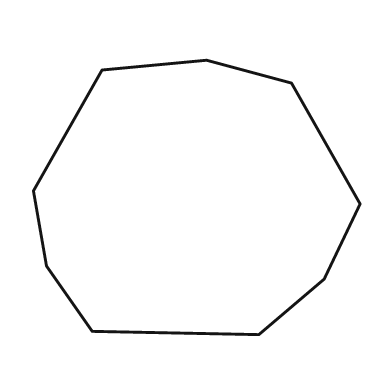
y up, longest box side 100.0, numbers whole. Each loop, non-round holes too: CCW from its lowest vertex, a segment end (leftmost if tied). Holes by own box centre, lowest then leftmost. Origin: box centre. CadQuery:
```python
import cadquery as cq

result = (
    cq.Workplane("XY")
    .moveTo(19.0, -42.0)
    .lineTo(39.0, -25.0)
    .lineTo(50.0, -2.0)
    .lineTo(29.0, 35.0)
    .lineTo(3.0, 42.0)
    .lineTo(-29.0, 39.0)
    .lineTo(-50.0, 2.0)
    .lineTo(-46.0, -21.0)
    .lineTo(-32.0, -41.0)
    .close()
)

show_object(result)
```